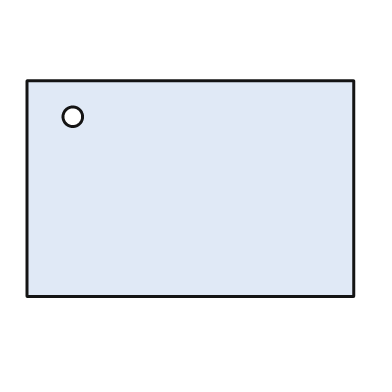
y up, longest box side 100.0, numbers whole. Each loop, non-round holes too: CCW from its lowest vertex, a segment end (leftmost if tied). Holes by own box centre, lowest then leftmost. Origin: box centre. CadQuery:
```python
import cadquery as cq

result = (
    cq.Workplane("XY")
    .moveTo(-50.0, -33.0)
    .lineTo(50.0, -33.0)
    .lineTo(50.0, 33.0)
    .lineTo(-50.0, 33.0)
    .close()
    .moveTo(-36.0, 22.0)
    .circle(3.0)
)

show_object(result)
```